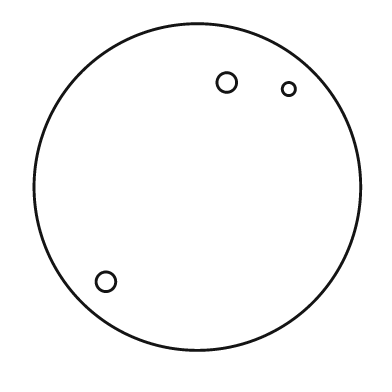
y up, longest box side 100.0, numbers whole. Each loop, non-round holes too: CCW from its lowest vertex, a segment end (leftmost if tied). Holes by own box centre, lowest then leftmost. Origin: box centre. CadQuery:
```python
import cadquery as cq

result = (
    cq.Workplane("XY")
    .moveTo(0.0, 0.0)
    .circle(50.0)
    .moveTo(-28.0, -29.0)
    .circle(3.0)
    .moveTo(28.0, 30.0)
    .circle(2.0)
    .moveTo(9.0, 32.0)
    .circle(3.0)
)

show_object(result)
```